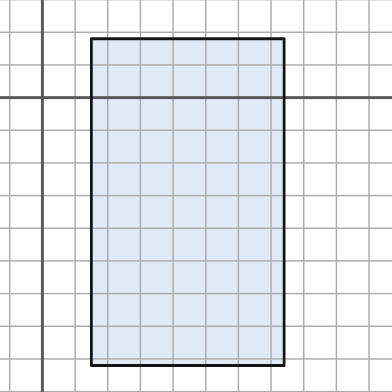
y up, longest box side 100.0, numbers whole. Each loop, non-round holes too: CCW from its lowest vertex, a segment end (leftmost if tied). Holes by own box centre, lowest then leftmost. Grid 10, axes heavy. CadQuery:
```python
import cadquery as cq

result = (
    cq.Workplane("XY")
    .moveTo(15.0, -82.0)
    .lineTo(74.0, -82.0)
    .lineTo(74.0, 18.0)
    .lineTo(15.0, 18.0)
    .close()
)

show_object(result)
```